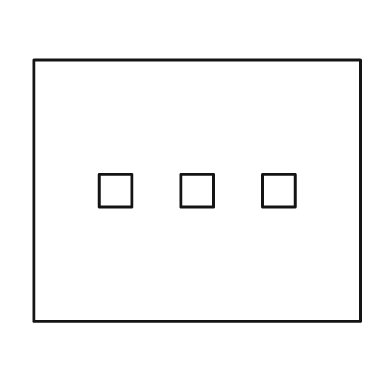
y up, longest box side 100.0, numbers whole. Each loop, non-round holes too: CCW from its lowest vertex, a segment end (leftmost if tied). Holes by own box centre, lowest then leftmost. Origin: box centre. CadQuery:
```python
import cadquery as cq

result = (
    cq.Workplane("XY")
    .moveTo(-50.0, -40.0)
    .lineTo(50.0, -40.0)
    .lineTo(50.0, 40.0)
    .lineTo(-50.0, 40.0)
    .close()
    .moveTo(-30.0, -5.0)
    .lineTo(-20.0, -5.0)
    .lineTo(-20.0, 5.0)
    .lineTo(-30.0, 5.0)
    .close()
    .moveTo(-5.0, -5.0)
    .lineTo(5.0, -5.0)
    .lineTo(5.0, 5.0)
    .lineTo(-5.0, 5.0)
    .close()
    .moveTo(20.0, -5.0)
    .lineTo(30.0, -5.0)
    .lineTo(30.0, 5.0)
    .lineTo(20.0, 5.0)
    .close()
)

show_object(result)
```